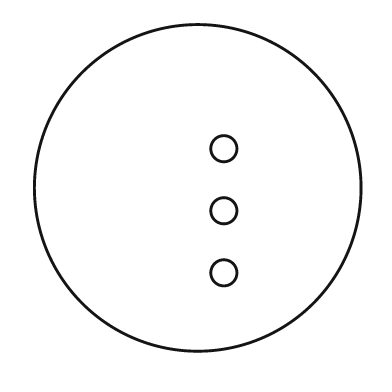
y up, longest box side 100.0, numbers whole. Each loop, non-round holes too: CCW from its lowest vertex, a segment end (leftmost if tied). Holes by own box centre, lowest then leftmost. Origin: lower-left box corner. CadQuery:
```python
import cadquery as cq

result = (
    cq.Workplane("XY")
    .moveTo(50.0, 50.0)
    .circle(50.0)
    .moveTo(58.0, 24.0)
    .circle(4.0)
    .moveTo(58.0, 43.0)
    .circle(4.0)
    .moveTo(58.0, 62.0)
    .circle(4.0)
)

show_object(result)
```